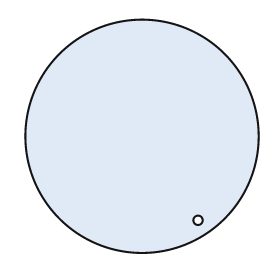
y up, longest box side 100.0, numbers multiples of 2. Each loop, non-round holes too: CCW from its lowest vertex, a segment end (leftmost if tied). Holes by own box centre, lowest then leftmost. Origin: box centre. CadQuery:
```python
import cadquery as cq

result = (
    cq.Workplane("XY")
    .moveTo(0.0, 0.0)
    .circle(50.0)
    .moveTo(24.0, -36.0)
    .circle(2.0)
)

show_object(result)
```